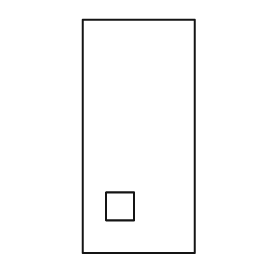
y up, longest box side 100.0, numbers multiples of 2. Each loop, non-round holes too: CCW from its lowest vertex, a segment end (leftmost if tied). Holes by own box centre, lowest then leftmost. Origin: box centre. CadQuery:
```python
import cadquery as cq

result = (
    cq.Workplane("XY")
    .moveTo(-24.0, -50.0)
    .lineTo(24.0, -50.0)
    .lineTo(24.0, 50.0)
    .lineTo(-24.0, 50.0)
    .close()
    .moveTo(-14.0, -36.0)
    .lineTo(-2.0, -36.0)
    .lineTo(-2.0, -24.0)
    .lineTo(-14.0, -24.0)
    .close()
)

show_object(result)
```